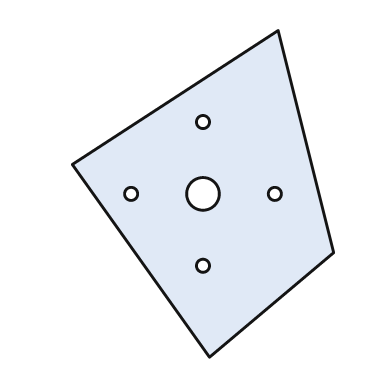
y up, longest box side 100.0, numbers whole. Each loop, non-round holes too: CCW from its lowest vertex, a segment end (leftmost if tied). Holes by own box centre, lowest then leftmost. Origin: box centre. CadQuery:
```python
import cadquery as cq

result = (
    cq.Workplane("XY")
    .moveTo(2.0, -50.0)
    .lineTo(40.0, -18.0)
    .lineTo(23.0, 50.0)
    .lineTo(-40.0, 9.0)
    .close()
    .moveTo(0.0, -22.0)
    .circle(2.0)
    .moveTo(-22.0, 0.0)
    .circle(2.0)
    .moveTo(0.0, 0.0)
    .circle(5.0)
    .moveTo(22.0, 0.0)
    .circle(2.0)
    .moveTo(0.0, 22.0)
    .circle(2.0)
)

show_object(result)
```